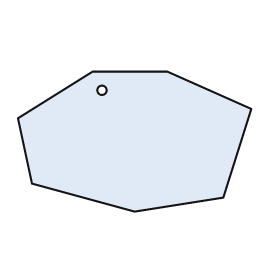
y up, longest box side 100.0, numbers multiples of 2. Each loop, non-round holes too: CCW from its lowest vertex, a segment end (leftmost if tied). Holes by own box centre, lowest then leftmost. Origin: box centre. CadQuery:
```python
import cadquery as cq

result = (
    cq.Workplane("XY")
    .moveTo(0.0, -30.0)
    .lineTo(38.0, -24.0)
    .lineTo(50.0, 14.0)
    .lineTo(14.0, 30.0)
    .lineTo(-18.0, 30.0)
    .lineTo(-50.0, 10.0)
    .lineTo(-44.0, -18.0)
    .close()
    .moveTo(-14.0, 22.0)
    .circle(2.0)
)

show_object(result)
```